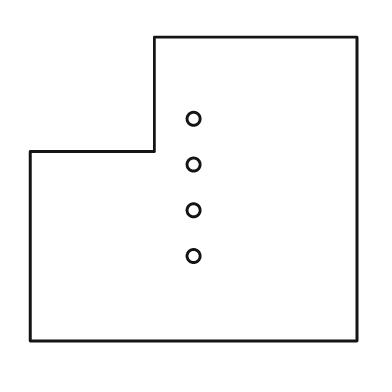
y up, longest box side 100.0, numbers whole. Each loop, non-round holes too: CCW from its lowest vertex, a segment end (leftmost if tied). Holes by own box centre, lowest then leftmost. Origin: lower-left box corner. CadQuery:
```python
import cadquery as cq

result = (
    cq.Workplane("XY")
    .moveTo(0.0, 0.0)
    .lineTo(100.0, 0.0)
    .lineTo(100.0, 93.0)
    .lineTo(38.0, 93.0)
    .lineTo(38.0, 58.0)
    .lineTo(0.0, 58.0)
    .close()
    .moveTo(50.0, 26.0)
    .circle(2.0)
    .moveTo(50.0, 40.0)
    .circle(2.0)
    .moveTo(50.0, 54.0)
    .circle(2.0)
    .moveTo(50.0, 68.0)
    .circle(2.0)
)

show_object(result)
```